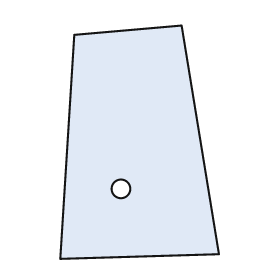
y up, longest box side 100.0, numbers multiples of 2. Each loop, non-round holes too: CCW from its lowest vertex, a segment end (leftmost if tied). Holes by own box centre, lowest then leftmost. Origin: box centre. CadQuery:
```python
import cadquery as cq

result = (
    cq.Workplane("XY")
    .moveTo(-34.0, -50.0)
    .lineTo(34.0, -48.0)
    .lineTo(18.0, 50.0)
    .lineTo(-28.0, 46.0)
    .close()
    .moveTo(-8.0, -20.0)
    .circle(4.0)
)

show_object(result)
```